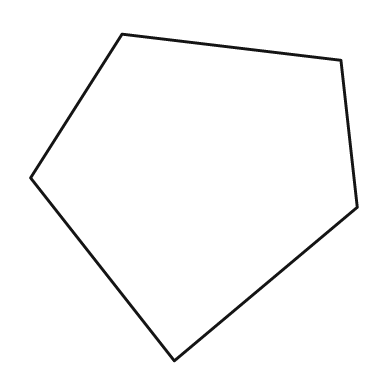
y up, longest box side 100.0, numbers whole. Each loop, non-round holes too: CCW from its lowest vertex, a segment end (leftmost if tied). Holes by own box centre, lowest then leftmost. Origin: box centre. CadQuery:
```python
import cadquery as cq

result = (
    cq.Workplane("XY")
    .moveTo(-6.0, -50.0)
    .lineTo(50.0, -3.0)
    .lineTo(45.0, 42.0)
    .lineTo(-22.0, 50.0)
    .lineTo(-50.0, 6.0)
    .close()
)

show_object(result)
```